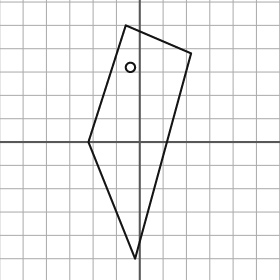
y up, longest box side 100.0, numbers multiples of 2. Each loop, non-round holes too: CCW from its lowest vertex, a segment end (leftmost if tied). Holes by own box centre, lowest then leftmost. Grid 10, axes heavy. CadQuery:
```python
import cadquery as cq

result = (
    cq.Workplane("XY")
    .moveTo(-2.0, -50.0)
    .lineTo(22.0, 38.0)
    .lineTo(-6.0, 50.0)
    .lineTo(-22.0, 0.0)
    .close()
    .moveTo(-4.0, 32.0)
    .circle(2.0)
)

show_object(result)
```